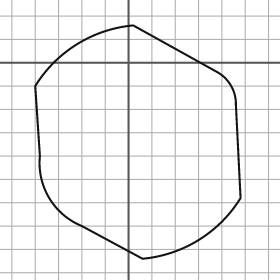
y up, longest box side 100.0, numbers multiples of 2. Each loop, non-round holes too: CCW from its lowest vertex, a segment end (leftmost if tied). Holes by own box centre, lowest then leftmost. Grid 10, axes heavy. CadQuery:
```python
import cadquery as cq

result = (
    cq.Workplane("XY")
    .moveTo(6.0, -84.0)
    .threePointArc((30.0, -76.0), (48.0, -58.0))
    .lineTo(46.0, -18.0)
    .threePointArc((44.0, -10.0), (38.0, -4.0))
    .lineTo(2.0, 16.0)
    .threePointArc((-22.0, 8.0), (-40.0, -10.0))
    .lineTo(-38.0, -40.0)
    .threePointArc((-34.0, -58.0), (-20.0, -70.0))
    .close()
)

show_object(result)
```